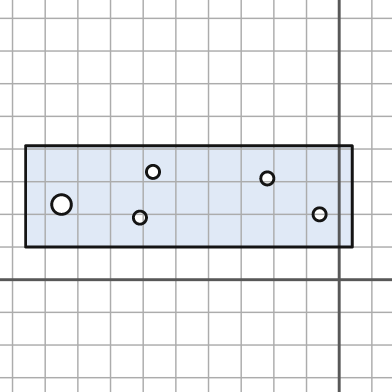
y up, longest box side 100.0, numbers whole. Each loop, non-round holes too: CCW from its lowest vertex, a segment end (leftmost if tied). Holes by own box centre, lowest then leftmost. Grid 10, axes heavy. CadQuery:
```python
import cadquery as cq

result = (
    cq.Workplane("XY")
    .moveTo(-96.0, 10.0)
    .lineTo(4.0, 10.0)
    .lineTo(4.0, 41.0)
    .lineTo(-96.0, 41.0)
    .close()
    .moveTo(-61.0, 19.0)
    .circle(2.0)
    .moveTo(-6.0, 20.0)
    .circle(2.0)
    .moveTo(-85.0, 23.0)
    .circle(3.0)
    .moveTo(-22.0, 31.0)
    .circle(2.0)
    .moveTo(-57.0, 33.0)
    .circle(2.0)
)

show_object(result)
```